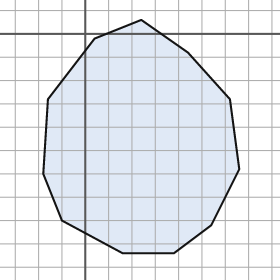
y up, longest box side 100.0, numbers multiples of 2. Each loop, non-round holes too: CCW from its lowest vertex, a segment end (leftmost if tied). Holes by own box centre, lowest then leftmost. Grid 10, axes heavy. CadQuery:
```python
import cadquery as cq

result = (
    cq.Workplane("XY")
    .moveTo(16.0, -94.0)
    .lineTo(38.0, -94.0)
    .lineTo(54.0, -82.0)
    .lineTo(66.0, -58.0)
    .lineTo(62.0, -28.0)
    .lineTo(44.0, -8.0)
    .lineTo(24.0, 6.0)
    .lineTo(4.0, -2.0)
    .lineTo(-16.0, -28.0)
    .lineTo(-18.0, -60.0)
    .lineTo(-10.0, -80.0)
    .close()
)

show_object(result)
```